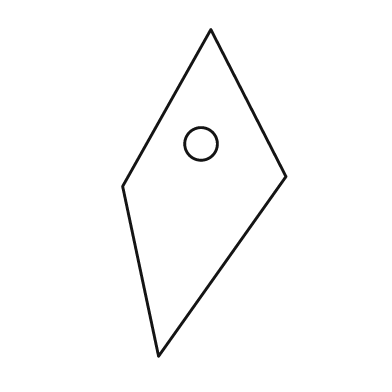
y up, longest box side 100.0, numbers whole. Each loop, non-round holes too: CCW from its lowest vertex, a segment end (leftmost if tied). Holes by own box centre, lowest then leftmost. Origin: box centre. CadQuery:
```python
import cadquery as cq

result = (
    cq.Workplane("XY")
    .moveTo(-14.0, -50.0)
    .lineTo(25.0, 5.0)
    .lineTo(2.0, 50.0)
    .lineTo(-25.0, 2.0)
    .close()
    .moveTo(-1.0, 15.0)
    .circle(5.0)
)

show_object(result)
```